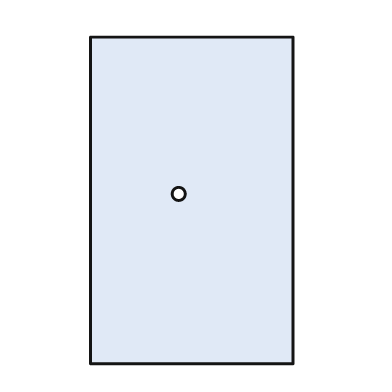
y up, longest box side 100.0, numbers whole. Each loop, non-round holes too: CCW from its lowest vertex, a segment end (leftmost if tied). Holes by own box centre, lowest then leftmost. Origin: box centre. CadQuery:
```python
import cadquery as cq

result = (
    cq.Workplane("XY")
    .moveTo(-31.0, -50.0)
    .lineTo(31.0, -50.0)
    .lineTo(31.0, 50.0)
    .lineTo(-31.0, 50.0)
    .close()
    .moveTo(-4.0, 2.0)
    .circle(2.0)
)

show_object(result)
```